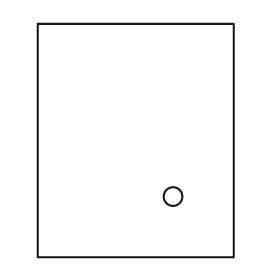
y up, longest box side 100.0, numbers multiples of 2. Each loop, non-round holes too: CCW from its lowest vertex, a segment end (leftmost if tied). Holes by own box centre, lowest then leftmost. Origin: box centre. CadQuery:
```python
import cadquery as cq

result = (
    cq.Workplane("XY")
    .moveTo(-42.0, -50.0)
    .lineTo(42.0, -50.0)
    .lineTo(42.0, 50.0)
    .lineTo(-42.0, 50.0)
    .close()
    .moveTo(16.0, -24.0)
    .circle(4.0)
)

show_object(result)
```